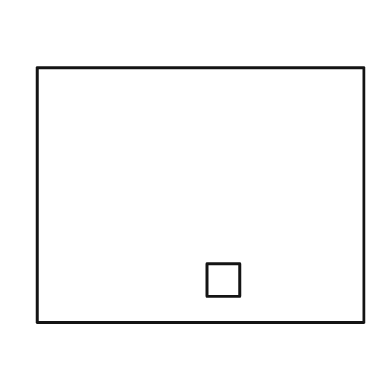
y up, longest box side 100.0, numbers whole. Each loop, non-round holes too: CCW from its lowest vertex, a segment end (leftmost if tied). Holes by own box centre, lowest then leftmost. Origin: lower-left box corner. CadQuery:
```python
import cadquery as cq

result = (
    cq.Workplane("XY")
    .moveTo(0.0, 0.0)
    .lineTo(100.0, 0.0)
    .lineTo(100.0, 78.0)
    .lineTo(0.0, 78.0)
    .close()
    .moveTo(52.0, 8.0)
    .lineTo(62.0, 8.0)
    .lineTo(62.0, 18.0)
    .lineTo(52.0, 18.0)
    .close()
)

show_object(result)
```